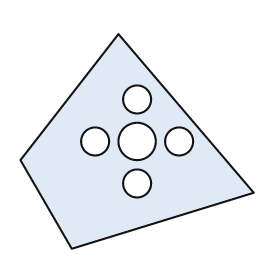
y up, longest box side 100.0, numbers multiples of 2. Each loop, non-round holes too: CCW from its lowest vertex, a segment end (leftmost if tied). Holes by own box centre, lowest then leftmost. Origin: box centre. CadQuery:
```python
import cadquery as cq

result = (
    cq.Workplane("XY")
    .moveTo(-28.0, -46.0)
    .lineTo(50.0, -22.0)
    .lineTo(-8.0, 46.0)
    .lineTo(-50.0, -8.0)
    .close()
    .moveTo(0.0, -18.0)
    .circle(6.0)
    .moveTo(-18.0, 0.0)
    .circle(6.0)
    .moveTo(0.0, 0.0)
    .circle(8.0)
    .moveTo(18.0, 0.0)
    .circle(6.0)
    .moveTo(0.0, 18.0)
    .circle(6.0)
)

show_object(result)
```